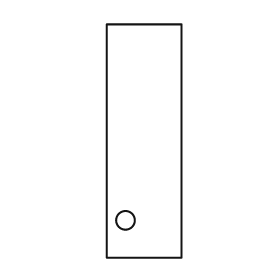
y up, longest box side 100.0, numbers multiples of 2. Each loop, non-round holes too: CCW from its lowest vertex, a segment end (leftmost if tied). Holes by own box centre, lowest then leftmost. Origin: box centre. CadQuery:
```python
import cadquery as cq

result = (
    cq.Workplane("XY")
    .moveTo(-16.0, -50.0)
    .lineTo(16.0, -50.0)
    .lineTo(16.0, 50.0)
    .lineTo(-16.0, 50.0)
    .close()
    .moveTo(-8.0, -34.0)
    .circle(4.0)
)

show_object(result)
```